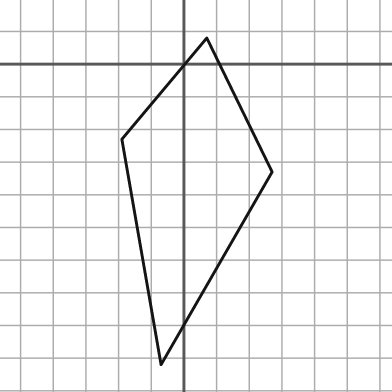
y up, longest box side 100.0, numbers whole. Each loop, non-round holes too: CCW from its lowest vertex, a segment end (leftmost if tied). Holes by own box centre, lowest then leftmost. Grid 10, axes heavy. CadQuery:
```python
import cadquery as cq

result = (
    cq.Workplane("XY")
    .moveTo(-7.0, -92.0)
    .lineTo(27.0, -33.0)
    .lineTo(7.0, 8.0)
    .lineTo(-19.0, -23.0)
    .close()
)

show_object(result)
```